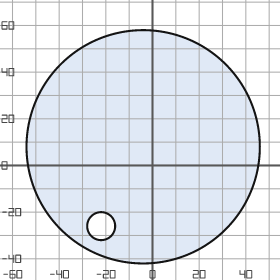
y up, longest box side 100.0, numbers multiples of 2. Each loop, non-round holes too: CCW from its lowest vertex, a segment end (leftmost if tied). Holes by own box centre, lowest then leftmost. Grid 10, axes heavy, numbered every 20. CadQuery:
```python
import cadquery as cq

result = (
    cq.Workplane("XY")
    .moveTo(-4.0, 8.0)
    .circle(50.0)
    .moveTo(-22.0, -26.0)
    .circle(6.0)
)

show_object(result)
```